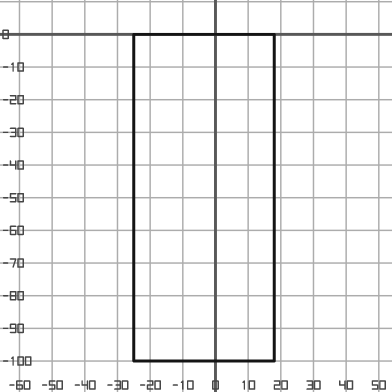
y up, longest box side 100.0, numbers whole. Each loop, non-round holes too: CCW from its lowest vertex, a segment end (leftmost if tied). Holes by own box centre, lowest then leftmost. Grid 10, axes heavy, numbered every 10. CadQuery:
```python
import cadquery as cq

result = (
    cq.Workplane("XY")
    .moveTo(-25.0, -100.0)
    .lineTo(18.0, -100.0)
    .lineTo(18.0, 0.0)
    .lineTo(-25.0, 0.0)
    .close()
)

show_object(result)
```